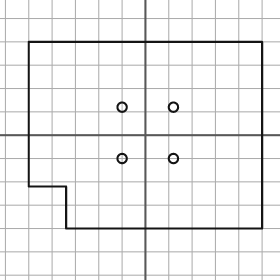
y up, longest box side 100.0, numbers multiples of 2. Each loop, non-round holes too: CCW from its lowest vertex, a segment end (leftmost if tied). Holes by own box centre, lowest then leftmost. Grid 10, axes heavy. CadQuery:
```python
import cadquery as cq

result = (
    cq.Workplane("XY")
    .moveTo(-34.0, -40.0)
    .lineTo(50.0, -40.0)
    .lineTo(50.0, 40.0)
    .lineTo(-50.0, 40.0)
    .lineTo(-50.0, -22.0)
    .lineTo(-34.0, -22.0)
    .close()
    .moveTo(-10.0, -10.0)
    .circle(2.0)
    .moveTo(12.0, -10.0)
    .circle(2.0)
    .moveTo(-10.0, 12.0)
    .circle(2.0)
    .moveTo(12.0, 12.0)
    .circle(2.0)
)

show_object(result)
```